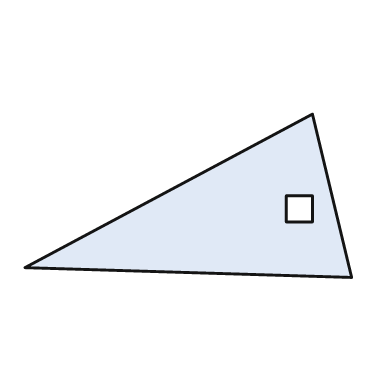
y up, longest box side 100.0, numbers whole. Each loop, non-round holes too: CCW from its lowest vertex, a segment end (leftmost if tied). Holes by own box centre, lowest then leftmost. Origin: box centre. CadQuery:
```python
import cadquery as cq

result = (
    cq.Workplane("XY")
    .moveTo(50.0, -25.0)
    .lineTo(38.0, 25.0)
    .lineTo(-50.0, -22.0)
    .close()
    .moveTo(30.0, -8.0)
    .lineTo(38.0, -8.0)
    .lineTo(38.0, 0.0)
    .lineTo(30.0, 0.0)
    .close()
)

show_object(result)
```